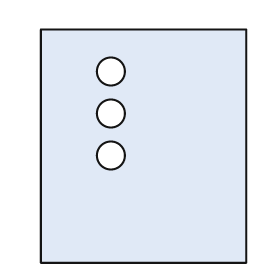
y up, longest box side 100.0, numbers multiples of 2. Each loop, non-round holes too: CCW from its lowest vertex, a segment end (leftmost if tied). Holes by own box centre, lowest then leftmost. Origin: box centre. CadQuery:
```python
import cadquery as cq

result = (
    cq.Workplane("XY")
    .moveTo(-44.0, -50.0)
    .lineTo(44.0, -50.0)
    .lineTo(44.0, 50.0)
    .lineTo(-44.0, 50.0)
    .close()
    .moveTo(-14.0, -4.0)
    .circle(6.0)
    .moveTo(-14.0, 14.0)
    .circle(6.0)
    .moveTo(-14.0, 32.0)
    .circle(6.0)
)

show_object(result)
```